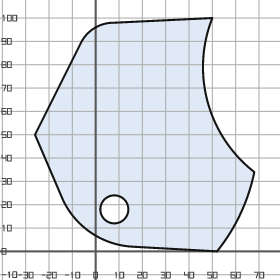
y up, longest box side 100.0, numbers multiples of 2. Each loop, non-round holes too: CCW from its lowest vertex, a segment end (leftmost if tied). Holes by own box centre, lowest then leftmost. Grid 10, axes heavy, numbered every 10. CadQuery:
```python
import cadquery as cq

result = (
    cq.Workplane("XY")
    .moveTo(52.0, 0.0)
    .threePointArc((62.0, 16.0), (68.0, 34.0))
    .threePointArc((48.0, 64.0), (50.0, 100.0))
    .lineTo(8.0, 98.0)
    .threePointArc((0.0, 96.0), (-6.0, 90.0))
    .lineTo(-26.0, 50.0)
    .lineTo(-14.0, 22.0)
    .threePointArc((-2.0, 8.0), (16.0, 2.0))
    .close()
    .moveTo(8.0, 18.0)
    .circle(6.0)
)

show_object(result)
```